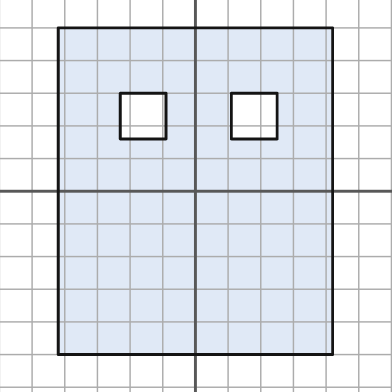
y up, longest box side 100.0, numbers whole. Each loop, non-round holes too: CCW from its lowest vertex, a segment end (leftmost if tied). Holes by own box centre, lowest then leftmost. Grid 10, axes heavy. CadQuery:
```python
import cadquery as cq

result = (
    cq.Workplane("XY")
    .moveTo(-42.0, -50.0)
    .lineTo(42.0, -50.0)
    .lineTo(42.0, 50.0)
    .lineTo(-42.0, 50.0)
    .close()
    .moveTo(-23.0, 16.0)
    .lineTo(-9.0, 16.0)
    .lineTo(-9.0, 30.0)
    .lineTo(-23.0, 30.0)
    .close()
    .moveTo(11.0, 16.0)
    .lineTo(25.0, 16.0)
    .lineTo(25.0, 30.0)
    .lineTo(11.0, 30.0)
    .close()
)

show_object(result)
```